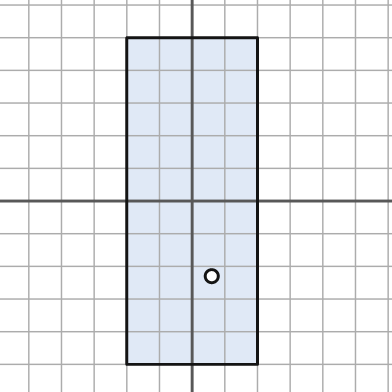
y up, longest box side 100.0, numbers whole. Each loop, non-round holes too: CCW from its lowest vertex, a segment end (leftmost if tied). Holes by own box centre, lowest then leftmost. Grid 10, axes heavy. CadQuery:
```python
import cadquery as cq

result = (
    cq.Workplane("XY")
    .moveTo(-20.0, -50.0)
    .lineTo(20.0, -50.0)
    .lineTo(20.0, 50.0)
    .lineTo(-20.0, 50.0)
    .close()
    .moveTo(6.0, -23.0)
    .circle(2.0)
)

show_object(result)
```